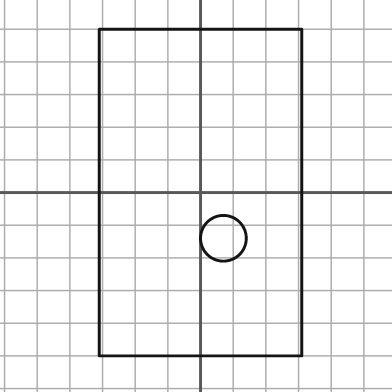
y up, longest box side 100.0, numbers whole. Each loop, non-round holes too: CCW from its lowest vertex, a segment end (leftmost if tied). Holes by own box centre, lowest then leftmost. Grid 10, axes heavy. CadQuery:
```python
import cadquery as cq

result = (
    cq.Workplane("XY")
    .moveTo(-31.0, -50.0)
    .lineTo(31.0, -50.0)
    .lineTo(31.0, 50.0)
    .lineTo(-31.0, 50.0)
    .close()
    .moveTo(7.0, -14.0)
    .circle(7.0)
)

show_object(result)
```